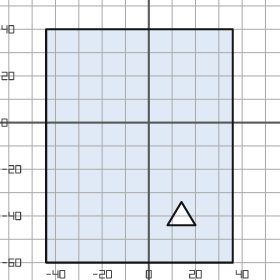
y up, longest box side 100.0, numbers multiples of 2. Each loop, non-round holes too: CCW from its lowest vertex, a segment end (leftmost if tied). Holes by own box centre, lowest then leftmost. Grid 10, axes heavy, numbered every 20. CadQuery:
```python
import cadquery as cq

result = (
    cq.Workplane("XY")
    .moveTo(-44.0, -60.0)
    .lineTo(36.0, -60.0)
    .lineTo(36.0, 40.0)
    .lineTo(-44.0, 40.0)
    .close()
    .moveTo(8.0, -44.0)
    .lineTo(20.0, -44.0)
    .lineTo(14.0, -34.0)
    .close()
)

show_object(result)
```